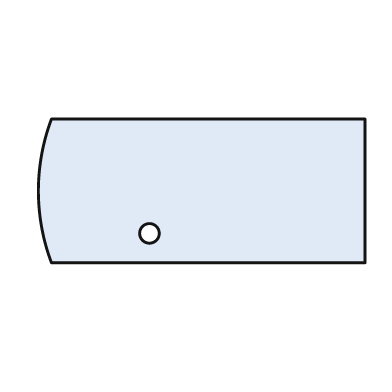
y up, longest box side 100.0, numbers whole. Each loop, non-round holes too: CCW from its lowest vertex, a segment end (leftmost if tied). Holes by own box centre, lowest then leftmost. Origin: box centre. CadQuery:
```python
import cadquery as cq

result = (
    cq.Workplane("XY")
    .moveTo(-46.0, -22.0)
    .lineTo(50.0, -22.0)
    .lineTo(50.0, 22.0)
    .lineTo(-46.0, 22.0)
    .threePointArc((-50.0, 0.0), (-46.0, -22.0))
    .close()
    .moveTo(-16.0, -13.0)
    .circle(3.0)
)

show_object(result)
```